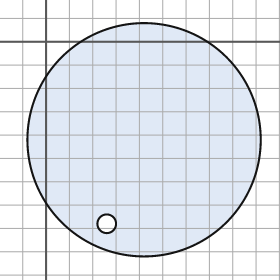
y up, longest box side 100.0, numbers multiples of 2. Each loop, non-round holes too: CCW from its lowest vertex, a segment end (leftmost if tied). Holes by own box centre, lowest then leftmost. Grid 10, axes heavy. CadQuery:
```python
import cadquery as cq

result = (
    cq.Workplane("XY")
    .moveTo(42.0, -42.0)
    .circle(50.0)
    .moveTo(26.0, -78.0)
    .circle(4.0)
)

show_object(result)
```